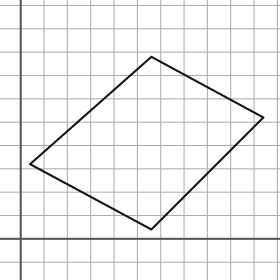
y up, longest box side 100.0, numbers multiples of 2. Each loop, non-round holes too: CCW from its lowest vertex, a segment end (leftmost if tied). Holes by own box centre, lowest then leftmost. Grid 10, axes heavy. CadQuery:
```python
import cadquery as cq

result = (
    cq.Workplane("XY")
    .moveTo(56.0, 4.0)
    .lineTo(104.0, 52.0)
    .lineTo(56.0, 78.0)
    .lineTo(4.0, 32.0)
    .close()
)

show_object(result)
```